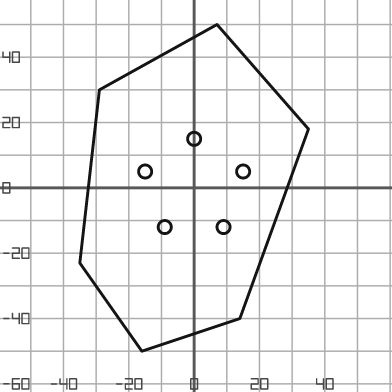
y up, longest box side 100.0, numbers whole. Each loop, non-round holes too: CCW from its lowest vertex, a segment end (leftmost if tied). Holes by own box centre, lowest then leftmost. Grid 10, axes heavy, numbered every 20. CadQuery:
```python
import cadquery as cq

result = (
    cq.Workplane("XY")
    .moveTo(-16.0, -50.0)
    .lineTo(14.0, -40.0)
    .lineTo(35.0, 18.0)
    .lineTo(7.0, 50.0)
    .lineTo(-29.0, 30.0)
    .lineTo(-35.0, -23.0)
    .close()
    .moveTo(-9.0, -12.0)
    .circle(2.0)
    .moveTo(9.0, -12.0)
    .circle(2.0)
    .moveTo(-15.0, 5.0)
    .circle(2.0)
    .moveTo(15.0, 5.0)
    .circle(2.0)
    .moveTo(0.0, 15.0)
    .circle(2.0)
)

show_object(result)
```